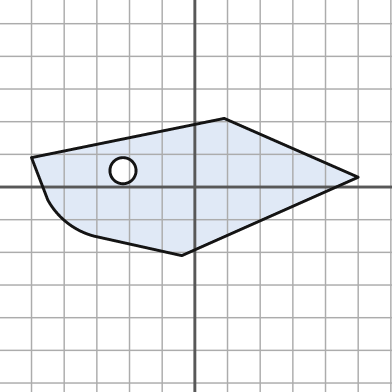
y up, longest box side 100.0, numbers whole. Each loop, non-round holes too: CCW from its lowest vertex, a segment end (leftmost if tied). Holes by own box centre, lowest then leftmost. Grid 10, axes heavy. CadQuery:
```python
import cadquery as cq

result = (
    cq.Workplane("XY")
    .moveTo(-4.0, -21.0)
    .lineTo(50.0, 3.0)
    .lineTo(9.0, 21.0)
    .lineTo(-50.0, 9.0)
    .lineTo(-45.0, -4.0)
    .threePointArc((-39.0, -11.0), (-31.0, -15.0))
    .close()
    .moveTo(-22.0, 5.0)
    .circle(4.0)
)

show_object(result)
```